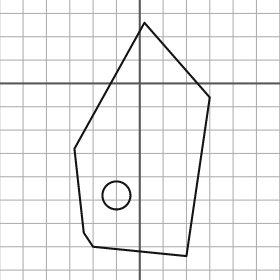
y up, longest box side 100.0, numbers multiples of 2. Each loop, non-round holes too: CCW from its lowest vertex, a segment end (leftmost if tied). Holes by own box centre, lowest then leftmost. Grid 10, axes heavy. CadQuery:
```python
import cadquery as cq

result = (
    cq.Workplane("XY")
    .moveTo(20.0, -74.0)
    .lineTo(30.0, -6.0)
    .lineTo(2.0, 26.0)
    .lineTo(-28.0, -28.0)
    .lineTo(-24.0, -64.0)
    .lineTo(-20.0, -70.0)
    .close()
    .moveTo(-10.0, -48.0)
    .circle(6.0)
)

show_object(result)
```